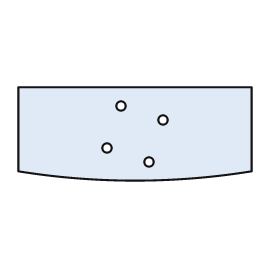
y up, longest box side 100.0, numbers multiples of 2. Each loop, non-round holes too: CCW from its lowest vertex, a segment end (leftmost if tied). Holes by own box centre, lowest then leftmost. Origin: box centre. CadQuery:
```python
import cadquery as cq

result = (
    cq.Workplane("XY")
    .moveTo(-50.0, -16.0)
    .threePointArc((0.0, -20.0), (50.0, -16.0))
    .lineTo(50.0, 20.0)
    .lineTo(-50.0, 20.0)
    .close()
    .moveTo(6.0, -12.0)
    .circle(2.0)
    .moveTo(-12.0, -6.0)
    .circle(2.0)
    .moveTo(12.0, 6.0)
    .circle(2.0)
    .moveTo(-6.0, 12.0)
    .circle(2.0)
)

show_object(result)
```